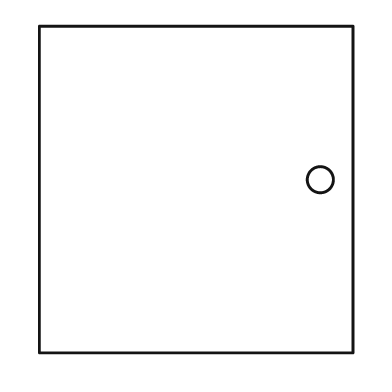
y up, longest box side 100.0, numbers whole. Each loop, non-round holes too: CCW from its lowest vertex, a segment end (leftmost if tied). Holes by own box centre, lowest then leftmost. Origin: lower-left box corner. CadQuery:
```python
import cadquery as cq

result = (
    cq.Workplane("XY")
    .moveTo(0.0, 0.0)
    .lineTo(96.0, 0.0)
    .lineTo(96.0, 100.0)
    .lineTo(0.0, 100.0)
    .close()
    .moveTo(86.0, 53.0)
    .circle(4.0)
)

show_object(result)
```